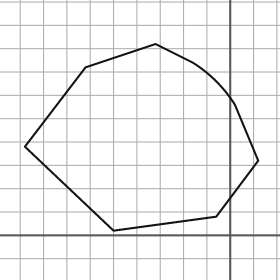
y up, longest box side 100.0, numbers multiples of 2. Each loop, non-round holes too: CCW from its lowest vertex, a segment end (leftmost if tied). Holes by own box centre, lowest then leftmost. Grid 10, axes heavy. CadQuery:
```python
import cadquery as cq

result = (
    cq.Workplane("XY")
    .moveTo(-50.0, 2.0)
    .lineTo(-6.0, 8.0)
    .lineTo(12.0, 32.0)
    .lineTo(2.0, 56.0)
    .threePointArc((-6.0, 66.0), (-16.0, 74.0))
    .lineTo(-32.0, 82.0)
    .lineTo(-62.0, 72.0)
    .lineTo(-88.0, 38.0)
    .close()
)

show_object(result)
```